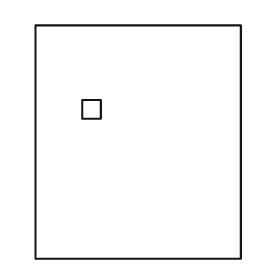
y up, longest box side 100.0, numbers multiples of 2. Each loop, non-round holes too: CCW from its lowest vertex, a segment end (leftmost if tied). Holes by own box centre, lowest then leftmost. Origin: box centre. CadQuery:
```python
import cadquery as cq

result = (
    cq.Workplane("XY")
    .moveTo(-44.0, -50.0)
    .lineTo(44.0, -50.0)
    .lineTo(44.0, 50.0)
    .lineTo(-44.0, 50.0)
    .close()
    .moveTo(-24.0, 10.0)
    .lineTo(-16.0, 10.0)
    .lineTo(-16.0, 18.0)
    .lineTo(-24.0, 18.0)
    .close()
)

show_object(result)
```